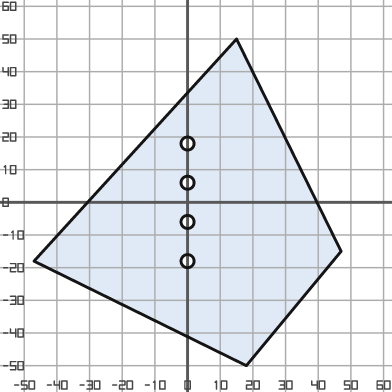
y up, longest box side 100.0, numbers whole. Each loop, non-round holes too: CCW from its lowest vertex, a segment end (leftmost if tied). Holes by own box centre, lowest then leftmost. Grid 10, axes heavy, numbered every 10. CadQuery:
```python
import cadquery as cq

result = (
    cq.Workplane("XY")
    .moveTo(18.0, -50.0)
    .lineTo(47.0, -15.0)
    .lineTo(15.0, 50.0)
    .lineTo(-47.0, -18.0)
    .close()
    .moveTo(0.0, -18.0)
    .circle(2.0)
    .moveTo(0.0, -6.0)
    .circle(2.0)
    .moveTo(0.0, 6.0)
    .circle(2.0)
    .moveTo(0.0, 18.0)
    .circle(2.0)
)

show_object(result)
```